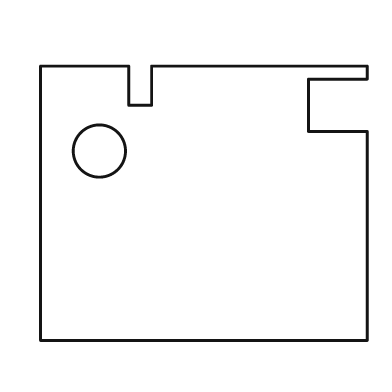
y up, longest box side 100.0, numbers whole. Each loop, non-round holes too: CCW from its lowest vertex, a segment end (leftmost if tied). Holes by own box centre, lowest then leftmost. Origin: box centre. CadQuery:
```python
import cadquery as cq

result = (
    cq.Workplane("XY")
    .moveTo(-50.0, -42.0)
    .lineTo(50.0, -42.0)
    .lineTo(50.0, 22.0)
    .lineTo(32.0, 22.0)
    .lineTo(32.0, 38.0)
    .lineTo(50.0, 38.0)
    .lineTo(50.0, 42.0)
    .lineTo(-16.0, 42.0)
    .lineTo(-16.0, 30.0)
    .lineTo(-23.0, 30.0)
    .lineTo(-23.0, 42.0)
    .lineTo(-50.0, 42.0)
    .close()
    .moveTo(-32.0, 16.0)
    .circle(8.0)
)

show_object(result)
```